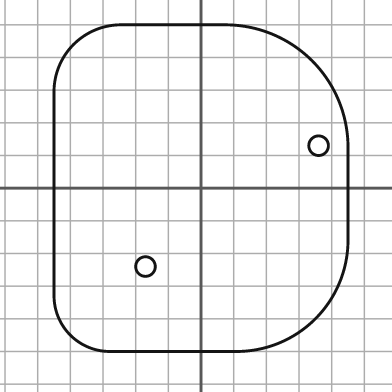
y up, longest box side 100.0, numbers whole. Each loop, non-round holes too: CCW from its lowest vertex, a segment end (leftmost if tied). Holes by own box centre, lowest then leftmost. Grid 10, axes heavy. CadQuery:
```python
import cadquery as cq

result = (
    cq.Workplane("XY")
    .moveTo(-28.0, -50.0)
    .lineTo(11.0, -50.0)
    .threePointArc((35.0, -40.0), (45.0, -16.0))
    .lineTo(45.0, 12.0)
    .threePointArc((34.0, 39.0), (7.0, 50.0))
    .lineTo(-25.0, 50.0)
    .threePointArc((-39.0, 44.0), (-45.0, 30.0))
    .lineTo(-45.0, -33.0)
    .threePointArc((-40.0, -45.0), (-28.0, -50.0))
    .close()
    .moveTo(-17.0, -24.0)
    .circle(3.0)
    .moveTo(36.0, 13.0)
    .circle(3.0)
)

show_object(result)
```